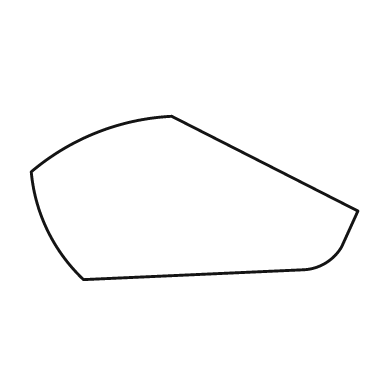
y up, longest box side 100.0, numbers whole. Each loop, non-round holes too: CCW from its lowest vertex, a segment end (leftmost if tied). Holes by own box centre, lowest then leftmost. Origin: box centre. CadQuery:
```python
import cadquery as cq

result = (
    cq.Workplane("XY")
    .moveTo(-34.0, -25.0)
    .lineTo(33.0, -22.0)
    .threePointArc((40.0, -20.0), (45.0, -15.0))
    .lineTo(50.0, -4.0)
    .lineTo(-7.0, 25.0)
    .threePointArc((-30.0, 20.0), (-50.0, 8.0))
    .threePointArc((-45.0, -10.0), (-34.0, -25.0))
    .close()
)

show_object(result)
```